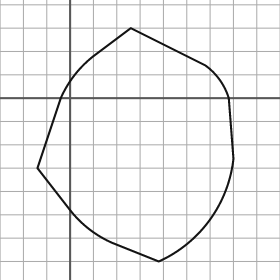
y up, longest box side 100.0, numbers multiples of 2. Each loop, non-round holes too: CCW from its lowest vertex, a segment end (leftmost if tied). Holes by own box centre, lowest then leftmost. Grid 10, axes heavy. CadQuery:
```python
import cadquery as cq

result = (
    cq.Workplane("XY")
    .moveTo(38.0, -70.0)
    .threePointArc((60.0, -52.0), (70.0, -26.0))
    .lineTo(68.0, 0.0)
    .threePointArc((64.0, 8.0), (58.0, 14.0))
    .lineTo(26.0, 30.0)
    .lineTo(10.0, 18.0)
    .threePointArc((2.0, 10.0), (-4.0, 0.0))
    .lineTo(-14.0, -30.0)
    .lineTo(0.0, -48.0)
    .threePointArc((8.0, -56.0), (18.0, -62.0))
    .close()
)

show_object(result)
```